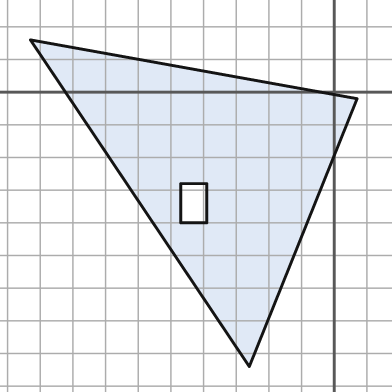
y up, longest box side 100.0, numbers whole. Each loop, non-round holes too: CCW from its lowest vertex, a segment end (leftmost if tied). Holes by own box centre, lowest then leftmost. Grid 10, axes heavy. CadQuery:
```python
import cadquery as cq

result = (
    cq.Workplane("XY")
    .moveTo(-26.0, -84.0)
    .lineTo(7.0, -2.0)
    .lineTo(-93.0, 16.0)
    .close()
    .moveTo(-47.0, -40.0)
    .lineTo(-39.0, -40.0)
    .lineTo(-39.0, -28.0)
    .lineTo(-47.0, -28.0)
    .close()
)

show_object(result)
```